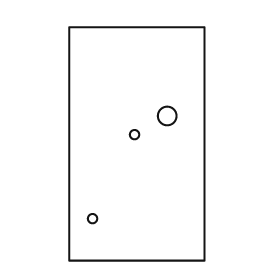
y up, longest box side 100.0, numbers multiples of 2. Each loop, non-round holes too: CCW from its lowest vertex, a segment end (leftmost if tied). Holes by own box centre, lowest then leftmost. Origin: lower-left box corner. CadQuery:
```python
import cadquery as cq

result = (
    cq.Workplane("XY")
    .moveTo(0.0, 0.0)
    .lineTo(58.0, 0.0)
    .lineTo(58.0, 100.0)
    .lineTo(0.0, 100.0)
    .close()
    .moveTo(10.0, 18.0)
    .circle(2.0)
    .moveTo(28.0, 54.0)
    .circle(2.0)
    .moveTo(42.0, 62.0)
    .circle(4.0)
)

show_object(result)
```